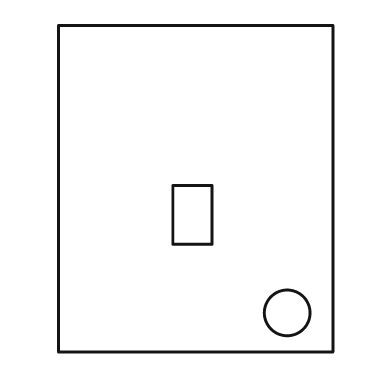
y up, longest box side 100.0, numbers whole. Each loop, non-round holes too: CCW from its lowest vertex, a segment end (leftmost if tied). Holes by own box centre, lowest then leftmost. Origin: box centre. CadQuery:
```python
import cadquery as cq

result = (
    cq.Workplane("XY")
    .moveTo(-42.0, -50.0)
    .lineTo(42.0, -50.0)
    .lineTo(42.0, 50.0)
    .lineTo(-42.0, 50.0)
    .close()
    .moveTo(28.0, -38.0)
    .circle(7.0)
    .moveTo(-7.0, -17.0)
    .lineTo(5.0, -17.0)
    .lineTo(5.0, 1.0)
    .lineTo(-7.0, 1.0)
    .close()
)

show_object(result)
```